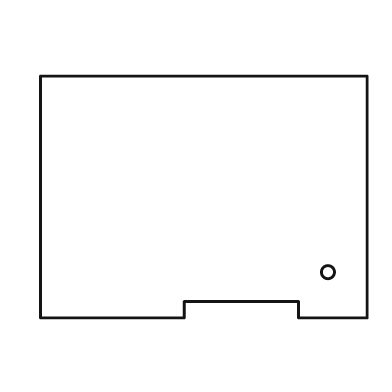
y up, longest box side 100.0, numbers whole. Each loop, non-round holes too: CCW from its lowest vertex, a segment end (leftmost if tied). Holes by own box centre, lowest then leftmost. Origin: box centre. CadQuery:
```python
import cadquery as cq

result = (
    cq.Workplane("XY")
    .moveTo(-50.0, -37.0)
    .lineTo(-6.0, -37.0)
    .lineTo(-6.0, -32.0)
    .lineTo(29.0, -32.0)
    .lineTo(29.0, -37.0)
    .lineTo(50.0, -37.0)
    .lineTo(50.0, 37.0)
    .lineTo(-50.0, 37.0)
    .close()
    .moveTo(38.0, -23.0)
    .circle(2.0)
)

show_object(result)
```